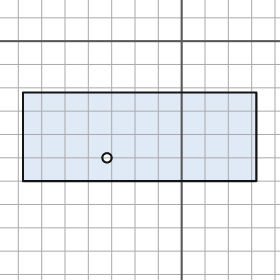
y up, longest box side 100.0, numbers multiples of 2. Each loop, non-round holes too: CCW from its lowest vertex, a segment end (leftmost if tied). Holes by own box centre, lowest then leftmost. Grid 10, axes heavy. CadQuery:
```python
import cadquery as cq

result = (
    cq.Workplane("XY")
    .moveTo(-68.0, -60.0)
    .lineTo(32.0, -60.0)
    .lineTo(32.0, -22.0)
    .lineTo(-68.0, -22.0)
    .close()
    .moveTo(-32.0, -50.0)
    .circle(2.0)
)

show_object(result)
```